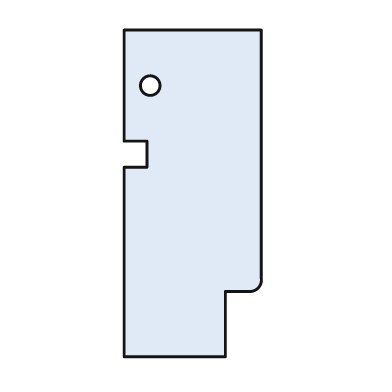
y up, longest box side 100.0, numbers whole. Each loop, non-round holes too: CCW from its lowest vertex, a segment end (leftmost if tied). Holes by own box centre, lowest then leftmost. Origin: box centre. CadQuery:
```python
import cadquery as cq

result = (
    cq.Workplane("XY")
    .moveTo(-21.0, -50.0)
    .lineTo(10.0, -50.0)
    .lineTo(10.0, -30.0)
    .lineTo(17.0, -30.0)
    .threePointArc((20.0, -29.0), (21.0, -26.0))
    .lineTo(21.0, 50.0)
    .lineTo(-21.0, 50.0)
    .lineTo(-21.0, 16.0)
    .lineTo(-14.0, 16.0)
    .lineTo(-14.0, 8.0)
    .lineTo(-21.0, 8.0)
    .close()
    .moveTo(-13.0, 33.0)
    .circle(3.0)
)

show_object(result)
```